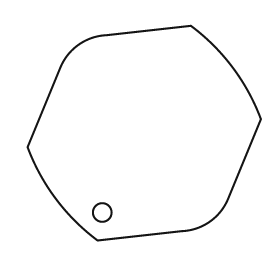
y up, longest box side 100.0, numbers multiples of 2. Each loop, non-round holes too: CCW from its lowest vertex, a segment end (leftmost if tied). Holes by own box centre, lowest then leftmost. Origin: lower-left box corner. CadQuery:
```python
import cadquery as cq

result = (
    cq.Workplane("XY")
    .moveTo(30.0, 0.0)
    .lineTo(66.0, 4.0)
    .threePointArc((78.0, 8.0), (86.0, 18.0))
    .lineTo(100.0, 52.0)
    .threePointArc((88.0, 74.0), (70.0, 92.0))
    .lineTo(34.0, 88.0)
    .threePointArc((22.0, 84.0), (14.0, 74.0))
    .lineTo(0.0, 40.0)
    .threePointArc((12.0, 18.0), (30.0, 0.0))
    .close()
    .moveTo(32.0, 12.0)
    .circle(4.0)
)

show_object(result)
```